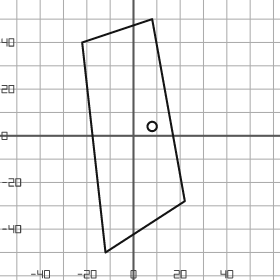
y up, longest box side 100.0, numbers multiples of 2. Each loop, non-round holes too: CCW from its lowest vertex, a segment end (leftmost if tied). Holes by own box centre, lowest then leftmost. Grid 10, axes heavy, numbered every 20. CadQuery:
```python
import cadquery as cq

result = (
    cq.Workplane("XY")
    .moveTo(-12.0, -50.0)
    .lineTo(22.0, -28.0)
    .lineTo(8.0, 50.0)
    .lineTo(-22.0, 40.0)
    .close()
    .moveTo(8.0, 4.0)
    .circle(2.0)
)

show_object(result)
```